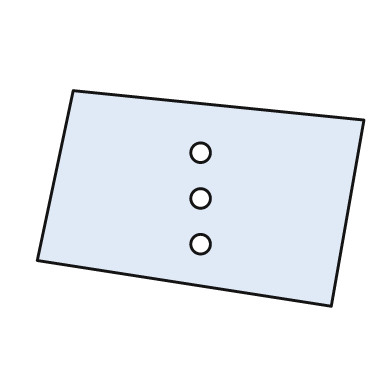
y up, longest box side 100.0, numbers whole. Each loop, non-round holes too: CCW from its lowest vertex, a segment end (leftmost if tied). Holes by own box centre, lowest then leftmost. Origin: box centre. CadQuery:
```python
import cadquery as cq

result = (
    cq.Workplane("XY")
    .moveTo(40.0, -33.0)
    .lineTo(50.0, 24.0)
    .lineTo(-39.0, 33.0)
    .lineTo(-50.0, -19.0)
    .close()
    .moveTo(0.0, -14.0)
    .circle(3.0)
    .moveTo(0.0, 0.0)
    .circle(3.0)
    .moveTo(0.0, 14.0)
    .circle(3.0)
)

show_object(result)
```